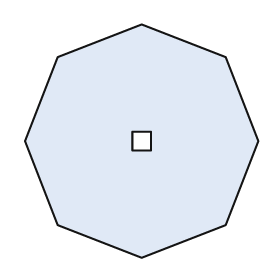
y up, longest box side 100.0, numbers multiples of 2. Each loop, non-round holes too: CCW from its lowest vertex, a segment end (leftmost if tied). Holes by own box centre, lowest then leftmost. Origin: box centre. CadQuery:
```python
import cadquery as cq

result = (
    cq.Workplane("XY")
    .moveTo(0.0, -50.0)
    .lineTo(36.0, -36.0)
    .lineTo(50.0, 0.0)
    .lineTo(36.0, 36.0)
    .lineTo(0.0, 50.0)
    .lineTo(-36.0, 36.0)
    .lineTo(-50.0, 0.0)
    .lineTo(-36.0, -36.0)
    .close()
    .moveTo(-4.0, -4.0)
    .lineTo(4.0, -4.0)
    .lineTo(4.0, 4.0)
    .lineTo(-4.0, 4.0)
    .close()
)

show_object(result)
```